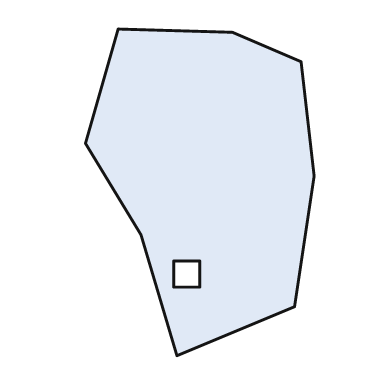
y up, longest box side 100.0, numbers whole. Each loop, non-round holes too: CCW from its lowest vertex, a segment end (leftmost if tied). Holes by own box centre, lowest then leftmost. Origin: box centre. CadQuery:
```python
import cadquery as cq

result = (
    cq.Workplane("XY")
    .moveTo(-7.0, -50.0)
    .lineTo(29.0, -35.0)
    .lineTo(35.0, 5.0)
    .lineTo(31.0, 40.0)
    .lineTo(10.0, 49.0)
    .lineTo(-25.0, 50.0)
    .lineTo(-35.0, 15.0)
    .lineTo(-18.0, -13.0)
    .close()
    .moveTo(-8.0, -29.0)
    .lineTo(0.0, -29.0)
    .lineTo(0.0, -21.0)
    .lineTo(-8.0, -21.0)
    .close()
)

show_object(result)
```